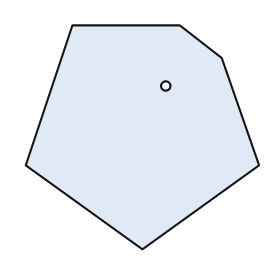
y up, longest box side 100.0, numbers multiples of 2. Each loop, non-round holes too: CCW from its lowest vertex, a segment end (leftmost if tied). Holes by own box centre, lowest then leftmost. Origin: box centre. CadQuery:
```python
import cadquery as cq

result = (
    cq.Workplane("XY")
    .moveTo(0.0, -48.0)
    .lineTo(50.0, -12.0)
    .lineTo(34.0, 34.0)
    .lineTo(16.0, 48.0)
    .lineTo(-30.0, 48.0)
    .lineTo(-50.0, -12.0)
    .close()
    .moveTo(10.0, 22.0)
    .circle(2.0)
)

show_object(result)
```